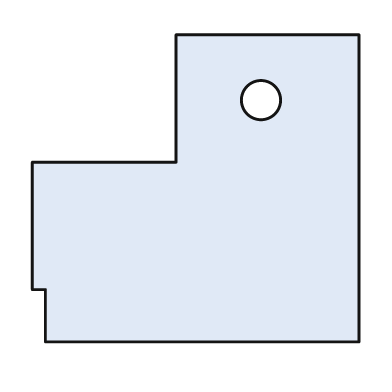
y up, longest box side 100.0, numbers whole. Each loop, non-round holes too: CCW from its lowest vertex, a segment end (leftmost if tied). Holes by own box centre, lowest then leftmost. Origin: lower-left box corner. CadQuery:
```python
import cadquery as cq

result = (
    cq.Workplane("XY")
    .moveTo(4.0, 0.0)
    .lineTo(100.0, 0.0)
    .lineTo(100.0, 94.0)
    .lineTo(44.0, 94.0)
    .lineTo(44.0, 55.0)
    .lineTo(0.0, 55.0)
    .lineTo(0.0, 16.0)
    .lineTo(4.0, 16.0)
    .close()
    .moveTo(70.0, 74.0)
    .circle(6.0)
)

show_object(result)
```